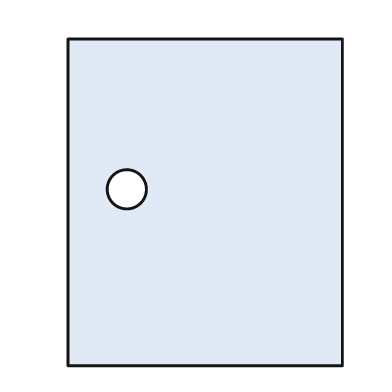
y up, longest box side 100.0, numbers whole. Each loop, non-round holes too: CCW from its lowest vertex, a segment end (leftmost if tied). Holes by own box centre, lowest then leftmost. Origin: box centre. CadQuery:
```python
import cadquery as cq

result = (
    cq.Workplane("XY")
    .moveTo(-42.0, -50.0)
    .lineTo(42.0, -50.0)
    .lineTo(42.0, 50.0)
    .lineTo(-42.0, 50.0)
    .close()
    .moveTo(-24.0, 4.0)
    .circle(6.0)
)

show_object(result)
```